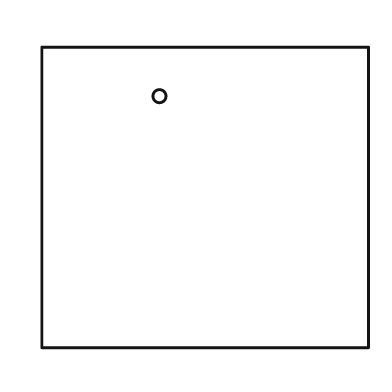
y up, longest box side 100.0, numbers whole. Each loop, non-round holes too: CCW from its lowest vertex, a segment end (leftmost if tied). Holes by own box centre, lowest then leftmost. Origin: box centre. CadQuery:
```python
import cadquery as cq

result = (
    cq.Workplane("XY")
    .moveTo(-50.0, -46.0)
    .lineTo(50.0, -46.0)
    .lineTo(50.0, 46.0)
    .lineTo(-50.0, 46.0)
    .close()
    .moveTo(-14.0, 31.0)
    .circle(2.0)
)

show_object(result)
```